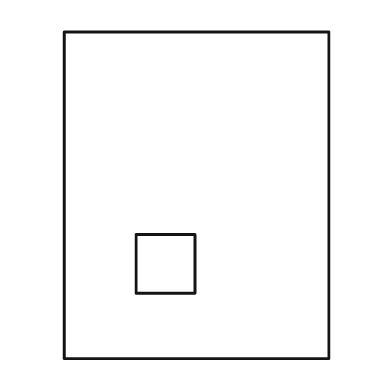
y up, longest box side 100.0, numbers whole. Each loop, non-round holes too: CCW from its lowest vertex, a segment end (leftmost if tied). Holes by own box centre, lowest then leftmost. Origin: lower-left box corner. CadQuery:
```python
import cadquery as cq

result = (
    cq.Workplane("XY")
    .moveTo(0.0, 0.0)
    .lineTo(81.0, 0.0)
    .lineTo(81.0, 100.0)
    .lineTo(0.0, 100.0)
    .close()
    .moveTo(22.0, 20.0)
    .lineTo(40.0, 20.0)
    .lineTo(40.0, 38.0)
    .lineTo(22.0, 38.0)
    .close()
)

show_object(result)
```